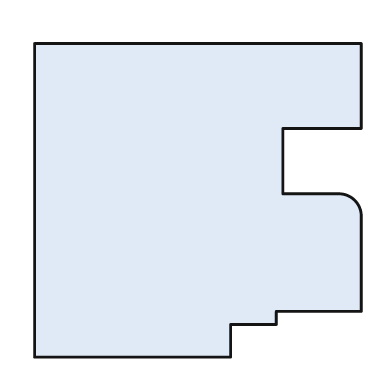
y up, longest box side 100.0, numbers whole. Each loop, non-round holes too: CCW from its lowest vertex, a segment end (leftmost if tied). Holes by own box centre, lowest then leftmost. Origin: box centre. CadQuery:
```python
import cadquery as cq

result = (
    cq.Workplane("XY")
    .moveTo(-50.0, -48.0)
    .lineTo(10.0, -48.0)
    .lineTo(10.0, -38.0)
    .lineTo(24.0, -38.0)
    .lineTo(24.0, -34.0)
    .lineTo(50.0, -34.0)
    .lineTo(50.0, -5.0)
    .threePointArc((48.0, 0.0), (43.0, 2.0))
    .lineTo(26.0, 2.0)
    .lineTo(26.0, 22.0)
    .lineTo(50.0, 22.0)
    .lineTo(50.0, 48.0)
    .lineTo(-50.0, 48.0)
    .close()
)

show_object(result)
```